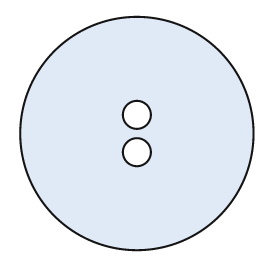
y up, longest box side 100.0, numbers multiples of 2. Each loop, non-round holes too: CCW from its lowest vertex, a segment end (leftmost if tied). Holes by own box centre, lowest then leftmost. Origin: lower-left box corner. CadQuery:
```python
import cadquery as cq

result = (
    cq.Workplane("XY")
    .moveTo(50.0, 50.0)
    .circle(50.0)
    .moveTo(50.0, 42.0)
    .circle(6.0)
    .moveTo(50.0, 58.0)
    .circle(6.0)
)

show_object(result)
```